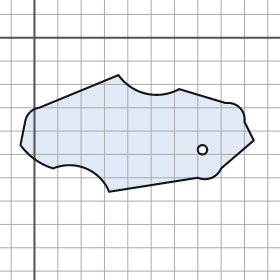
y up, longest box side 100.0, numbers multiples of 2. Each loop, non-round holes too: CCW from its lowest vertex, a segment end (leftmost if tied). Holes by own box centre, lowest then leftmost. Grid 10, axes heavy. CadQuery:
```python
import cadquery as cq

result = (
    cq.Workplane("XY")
    .moveTo(32.0, -66.0)
    .lineTo(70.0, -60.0)
    .threePointArc((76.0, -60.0), (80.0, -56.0))
    .lineTo(94.0, -44.0)
    .lineTo(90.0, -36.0)
    .threePointArc((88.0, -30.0), (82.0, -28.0))
    .lineTo(62.0, -22.0)
    .threePointArc((48.0, -24.0), (36.0, -16.0))
    .lineTo(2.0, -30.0)
    .threePointArc((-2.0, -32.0), (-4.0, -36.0))
    .lineTo(-6.0, -46.0)
    .threePointArc((0.0, -52.0), (8.0, -56.0))
    .threePointArc((22.0, -56.0), (32.0, -66.0))
    .close()
    .moveTo(72.0, -48.0)
    .circle(2.0)
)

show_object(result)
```